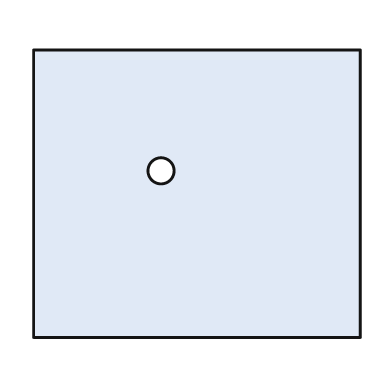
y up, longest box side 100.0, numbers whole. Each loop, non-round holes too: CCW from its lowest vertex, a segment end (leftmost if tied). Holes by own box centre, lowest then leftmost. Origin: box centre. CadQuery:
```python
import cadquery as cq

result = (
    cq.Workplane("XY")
    .moveTo(-50.0, -44.0)
    .lineTo(50.0, -44.0)
    .lineTo(50.0, 44.0)
    .lineTo(-50.0, 44.0)
    .close()
    .moveTo(-11.0, 7.0)
    .circle(4.0)
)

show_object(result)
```